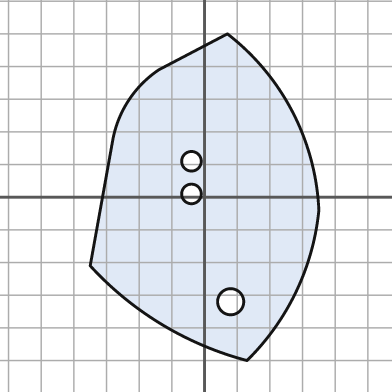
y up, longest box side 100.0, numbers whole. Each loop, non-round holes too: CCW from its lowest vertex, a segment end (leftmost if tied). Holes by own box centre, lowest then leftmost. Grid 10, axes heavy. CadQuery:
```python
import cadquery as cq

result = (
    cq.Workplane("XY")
    .moveTo(13.0, -50.0)
    .threePointArc((28.0, -29.0), (35.0, -4.0))
    .threePointArc((27.0, 26.0), (7.0, 50.0))
    .lineTo(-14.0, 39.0)
    .threePointArc((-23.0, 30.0), (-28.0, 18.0))
    .lineTo(-35.0, -21.0)
    .threePointArc((-13.0, -39.0), (13.0, -50.0))
    .close()
    .moveTo(8.0, -32.0)
    .circle(4.0)
    .moveTo(-4.0, 1.0)
    .circle(3.0)
    .moveTo(-4.0, 11.0)
    .circle(3.0)
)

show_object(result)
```